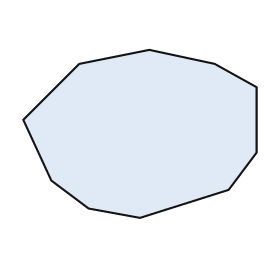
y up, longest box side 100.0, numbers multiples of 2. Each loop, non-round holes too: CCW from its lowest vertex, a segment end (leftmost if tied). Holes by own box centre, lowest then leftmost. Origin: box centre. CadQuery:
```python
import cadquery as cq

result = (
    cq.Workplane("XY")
    .moveTo(0.0, -36.0)
    .lineTo(38.0, -24.0)
    .lineTo(50.0, -8.0)
    .lineTo(50.0, 20.0)
    .lineTo(32.0, 30.0)
    .lineTo(4.0, 36.0)
    .lineTo(-26.0, 30.0)
    .lineTo(-50.0, 6.0)
    .lineTo(-38.0, -20.0)
    .lineTo(-22.0, -32.0)
    .close()
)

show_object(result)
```